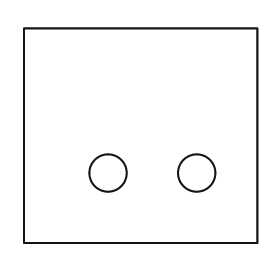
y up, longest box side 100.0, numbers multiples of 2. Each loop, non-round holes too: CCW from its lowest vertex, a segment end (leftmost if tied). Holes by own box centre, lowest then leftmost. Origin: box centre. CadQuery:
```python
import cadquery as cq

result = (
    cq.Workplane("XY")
    .moveTo(-50.0, -46.0)
    .lineTo(50.0, -46.0)
    .lineTo(50.0, 46.0)
    .lineTo(-50.0, 46.0)
    .close()
    .moveTo(-14.0, -16.0)
    .circle(8.0)
    .moveTo(24.0, -16.0)
    .circle(8.0)
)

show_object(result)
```